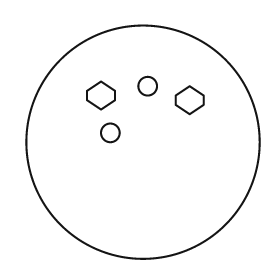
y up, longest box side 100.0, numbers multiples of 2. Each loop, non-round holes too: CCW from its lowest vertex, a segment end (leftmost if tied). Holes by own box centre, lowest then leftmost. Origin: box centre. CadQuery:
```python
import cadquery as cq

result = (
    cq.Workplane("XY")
    .moveTo(0.0, 0.0)
    .circle(50.0)
    .moveTo(-14.0, 4.0)
    .circle(4.0)
    .moveTo(20.0, 12.0)
    .lineTo(26.0, 16.0)
    .lineTo(26.0, 20.0)
    .lineTo(20.0, 24.0)
    .lineTo(14.0, 20.0)
    .lineTo(14.0, 16.0)
    .close()
    .moveTo(-18.0, 14.0)
    .lineTo(-12.0, 18.0)
    .lineTo(-12.0, 22.0)
    .lineTo(-18.0, 26.0)
    .lineTo(-24.0, 22.0)
    .lineTo(-24.0, 18.0)
    .close()
    .moveTo(2.0, 24.0)
    .circle(4.0)
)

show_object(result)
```